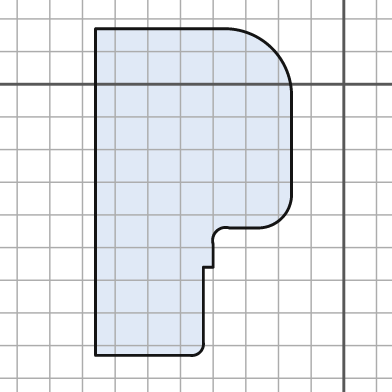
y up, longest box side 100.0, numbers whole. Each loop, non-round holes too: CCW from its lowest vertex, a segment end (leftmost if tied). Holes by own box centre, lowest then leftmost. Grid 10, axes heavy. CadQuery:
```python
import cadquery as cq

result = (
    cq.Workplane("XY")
    .moveTo(-76.0, -83.0)
    .lineTo(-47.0, -83.0)
    .threePointArc((-44.0, -82.0), (-43.0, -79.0))
    .lineTo(-43.0, -56.0)
    .lineTo(-40.0, -56.0)
    .lineTo(-40.0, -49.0)
    .threePointArc((-39.0, -45.0), (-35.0, -44.0))
    .lineTo(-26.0, -44.0)
    .threePointArc((-19.0, -41.0), (-16.0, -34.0))
    .lineTo(-16.0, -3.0)
    .threePointArc((-22.0, 11.0), (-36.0, 17.0))
    .lineTo(-76.0, 17.0)
    .close()
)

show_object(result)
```